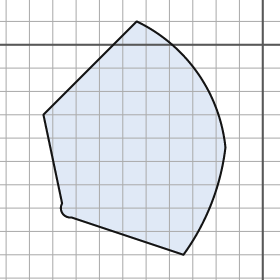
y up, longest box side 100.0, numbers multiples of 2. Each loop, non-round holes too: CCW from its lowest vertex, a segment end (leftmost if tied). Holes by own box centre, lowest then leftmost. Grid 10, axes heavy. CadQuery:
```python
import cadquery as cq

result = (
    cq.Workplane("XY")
    .moveTo(-34.0, -90.0)
    .threePointArc((-22.0, -68.0), (-16.0, -44.0))
    .threePointArc((-28.0, -12.0), (-54.0, 10.0))
    .lineTo(-94.0, -30.0)
    .lineTo(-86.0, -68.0)
    .threePointArc((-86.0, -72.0), (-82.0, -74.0))
    .close()
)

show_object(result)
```